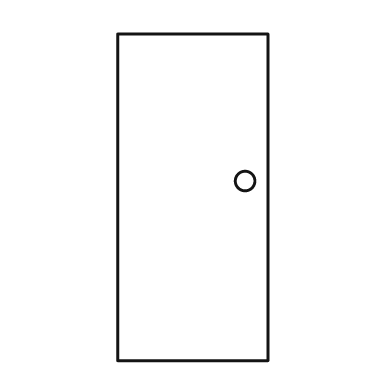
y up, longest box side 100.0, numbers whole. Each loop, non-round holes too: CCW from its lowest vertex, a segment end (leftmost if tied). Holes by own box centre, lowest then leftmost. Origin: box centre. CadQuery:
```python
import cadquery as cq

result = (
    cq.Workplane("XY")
    .moveTo(-23.0, -50.0)
    .lineTo(23.0, -50.0)
    .lineTo(23.0, 50.0)
    .lineTo(-23.0, 50.0)
    .close()
    .moveTo(16.0, 5.0)
    .circle(3.0)
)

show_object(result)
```